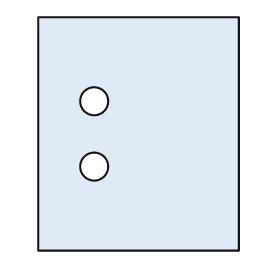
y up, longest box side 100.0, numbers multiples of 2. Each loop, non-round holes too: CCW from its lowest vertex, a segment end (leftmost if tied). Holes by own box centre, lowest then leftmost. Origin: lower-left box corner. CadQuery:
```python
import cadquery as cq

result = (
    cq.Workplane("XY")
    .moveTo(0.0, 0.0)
    .lineTo(86.0, 0.0)
    .lineTo(86.0, 100.0)
    .lineTo(0.0, 100.0)
    .close()
    .moveTo(24.0, 36.0)
    .circle(6.0)
    .moveTo(24.0, 64.0)
    .circle(6.0)
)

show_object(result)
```